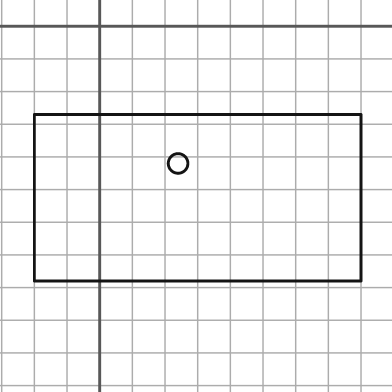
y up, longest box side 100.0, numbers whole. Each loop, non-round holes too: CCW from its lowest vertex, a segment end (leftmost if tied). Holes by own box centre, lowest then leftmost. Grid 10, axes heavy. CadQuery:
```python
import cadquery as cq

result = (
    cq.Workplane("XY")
    .moveTo(-20.0, -78.0)
    .lineTo(80.0, -78.0)
    .lineTo(80.0, -27.0)
    .lineTo(-20.0, -27.0)
    .close()
    .moveTo(24.0, -42.0)
    .circle(3.0)
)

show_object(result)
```